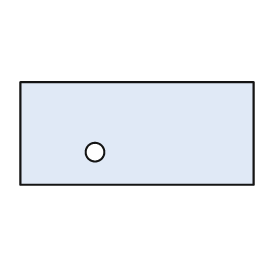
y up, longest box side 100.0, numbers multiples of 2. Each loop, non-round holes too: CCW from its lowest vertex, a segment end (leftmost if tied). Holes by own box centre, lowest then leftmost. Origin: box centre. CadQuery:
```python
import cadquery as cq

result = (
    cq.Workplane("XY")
    .moveTo(-50.0, -22.0)
    .lineTo(50.0, -22.0)
    .lineTo(50.0, 22.0)
    .lineTo(-50.0, 22.0)
    .close()
    .moveTo(-18.0, -8.0)
    .circle(4.0)
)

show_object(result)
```